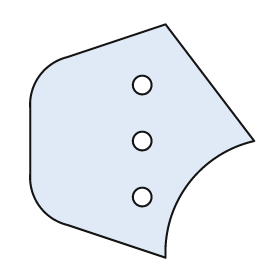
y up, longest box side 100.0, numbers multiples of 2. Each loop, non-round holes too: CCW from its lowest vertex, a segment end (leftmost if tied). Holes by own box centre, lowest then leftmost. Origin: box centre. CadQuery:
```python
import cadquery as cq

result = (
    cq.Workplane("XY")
    .moveTo(10.0, -50.0)
    .threePointArc((20.0, -18.0), (48.0, 0.0))
    .lineTo(10.0, 50.0)
    .lineTo(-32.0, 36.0)
    .threePointArc((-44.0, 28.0), (-48.0, 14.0))
    .lineTo(-48.0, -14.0)
    .threePointArc((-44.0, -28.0), (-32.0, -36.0))
    .close()
    .moveTo(0.0, -24.0)
    .circle(4.0)
    .moveTo(0.0, 0.0)
    .circle(4.0)
    .moveTo(0.0, 24.0)
    .circle(4.0)
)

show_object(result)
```